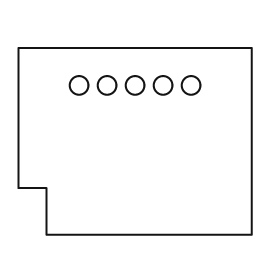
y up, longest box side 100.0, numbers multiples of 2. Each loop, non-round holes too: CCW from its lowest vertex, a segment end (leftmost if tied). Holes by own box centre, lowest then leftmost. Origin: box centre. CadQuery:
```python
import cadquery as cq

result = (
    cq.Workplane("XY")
    .moveTo(-38.0, -40.0)
    .lineTo(50.0, -40.0)
    .lineTo(50.0, 40.0)
    .lineTo(-50.0, 40.0)
    .lineTo(-50.0, -20.0)
    .lineTo(-38.0, -20.0)
    .close()
    .moveTo(-24.0, 24.0)
    .circle(4.0)
    .moveTo(-12.0, 24.0)
    .circle(4.0)
    .moveTo(0.0, 24.0)
    .circle(4.0)
    .moveTo(12.0, 24.0)
    .circle(4.0)
    .moveTo(24.0, 24.0)
    .circle(4.0)
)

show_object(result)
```